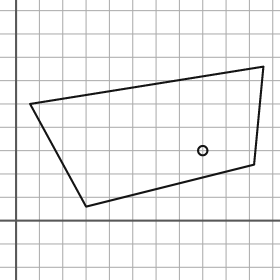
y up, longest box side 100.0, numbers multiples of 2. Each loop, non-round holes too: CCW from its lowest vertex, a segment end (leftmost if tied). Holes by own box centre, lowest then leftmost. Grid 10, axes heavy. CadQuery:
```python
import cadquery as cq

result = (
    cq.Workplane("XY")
    .moveTo(30.0, 6.0)
    .lineTo(102.0, 24.0)
    .lineTo(106.0, 66.0)
    .lineTo(6.0, 50.0)
    .close()
    .moveTo(80.0, 30.0)
    .circle(2.0)
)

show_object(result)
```